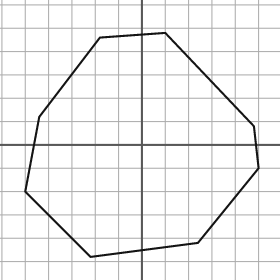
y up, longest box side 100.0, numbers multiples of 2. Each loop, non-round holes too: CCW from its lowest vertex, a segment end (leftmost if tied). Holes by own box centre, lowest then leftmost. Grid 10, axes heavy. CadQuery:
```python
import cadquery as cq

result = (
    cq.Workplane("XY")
    .moveTo(-22.0, -48.0)
    .lineTo(24.0, -42.0)
    .lineTo(50.0, -10.0)
    .lineTo(48.0, 8.0)
    .lineTo(10.0, 48.0)
    .lineTo(-18.0, 46.0)
    .lineTo(-44.0, 12.0)
    .lineTo(-50.0, -20.0)
    .close()
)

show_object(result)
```